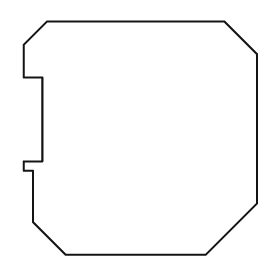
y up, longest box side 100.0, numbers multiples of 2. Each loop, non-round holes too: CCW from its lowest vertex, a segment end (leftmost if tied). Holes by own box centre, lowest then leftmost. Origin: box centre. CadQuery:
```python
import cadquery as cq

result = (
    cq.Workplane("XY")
    .moveTo(-32.0, -50.0)
    .lineTo(28.0, -50.0)
    .lineTo(50.0, -28.0)
    .lineTo(50.0, 36.0)
    .lineTo(36.0, 50.0)
    .lineTo(-40.0, 50.0)
    .lineTo(-50.0, 40.0)
    .lineTo(-50.0, 26.0)
    .lineTo(-42.0, 26.0)
    .lineTo(-42.0, -10.0)
    .lineTo(-50.0, -10.0)
    .lineTo(-50.0, -14.0)
    .lineTo(-46.0, -14.0)
    .lineTo(-46.0, -36.0)
    .close()
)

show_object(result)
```